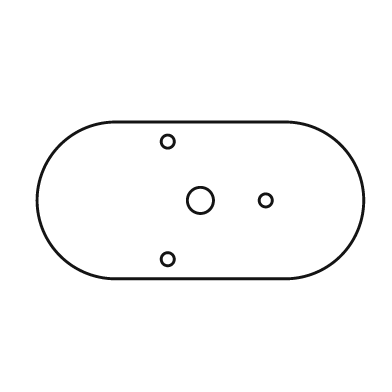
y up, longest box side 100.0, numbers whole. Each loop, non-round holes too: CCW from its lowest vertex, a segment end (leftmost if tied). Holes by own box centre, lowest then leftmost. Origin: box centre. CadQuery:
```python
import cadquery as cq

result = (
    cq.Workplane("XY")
    .moveTo(-26.0, -24.0)
    .lineTo(26.0, -24.0)
    .threePointArc((50.0, 0.0), (26.0, 24.0))
    .lineTo(-26.0, 24.0)
    .threePointArc((-50.0, 0.0), (-26.0, -24.0))
    .close()
    .moveTo(-10.0, -18.0)
    .circle(2.0)
    .moveTo(0.0, 0.0)
    .circle(4.0)
    .moveTo(20.0, 0.0)
    .circle(2.0)
    .moveTo(-10.0, 18.0)
    .circle(2.0)
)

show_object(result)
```